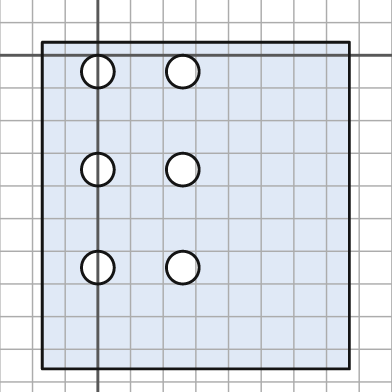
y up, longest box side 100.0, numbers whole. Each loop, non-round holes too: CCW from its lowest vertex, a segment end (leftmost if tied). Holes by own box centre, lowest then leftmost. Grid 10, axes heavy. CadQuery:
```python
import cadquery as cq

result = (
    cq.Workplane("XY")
    .moveTo(-17.0, -96.0)
    .lineTo(77.0, -96.0)
    .lineTo(77.0, 4.0)
    .lineTo(-17.0, 4.0)
    .close()
    .moveTo(0.0, -65.0)
    .circle(5.0)
    .moveTo(26.0, -65.0)
    .circle(5.0)
    .moveTo(0.0, -35.0)
    .circle(5.0)
    .moveTo(26.0, -35.0)
    .circle(5.0)
    .moveTo(0.0, -5.0)
    .circle(5.0)
    .moveTo(26.0, -5.0)
    .circle(5.0)
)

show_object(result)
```